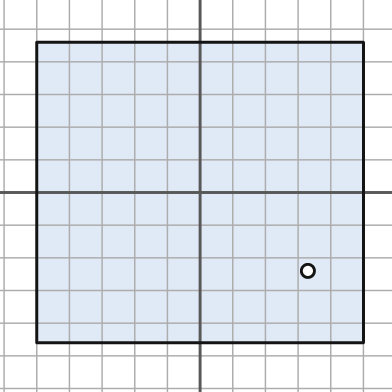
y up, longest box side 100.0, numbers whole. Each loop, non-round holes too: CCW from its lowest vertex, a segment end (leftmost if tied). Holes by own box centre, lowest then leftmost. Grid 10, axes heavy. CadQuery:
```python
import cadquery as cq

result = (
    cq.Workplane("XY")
    .moveTo(-50.0, -46.0)
    .lineTo(50.0, -46.0)
    .lineTo(50.0, 46.0)
    .lineTo(-50.0, 46.0)
    .close()
    .moveTo(33.0, -24.0)
    .circle(2.0)
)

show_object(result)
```